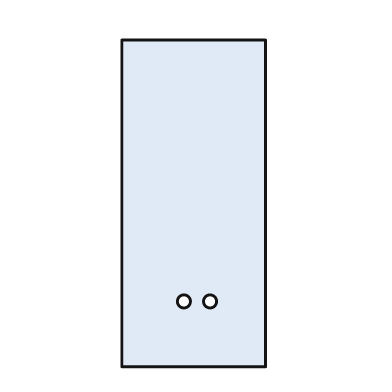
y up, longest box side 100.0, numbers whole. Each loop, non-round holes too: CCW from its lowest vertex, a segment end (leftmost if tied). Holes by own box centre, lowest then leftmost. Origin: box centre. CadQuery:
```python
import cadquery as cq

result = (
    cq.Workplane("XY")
    .moveTo(-22.0, -50.0)
    .lineTo(22.0, -50.0)
    .lineTo(22.0, 50.0)
    .lineTo(-22.0, 50.0)
    .close()
    .moveTo(-3.0, -30.0)
    .circle(2.0)
    .moveTo(5.0, -30.0)
    .circle(2.0)
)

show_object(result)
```